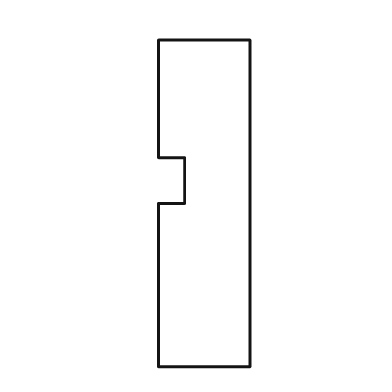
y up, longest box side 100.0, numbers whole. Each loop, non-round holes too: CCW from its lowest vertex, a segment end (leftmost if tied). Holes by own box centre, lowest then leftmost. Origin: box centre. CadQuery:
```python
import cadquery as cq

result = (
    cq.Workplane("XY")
    .moveTo(-14.0, -50.0)
    .lineTo(14.0, -50.0)
    .lineTo(14.0, 50.0)
    .lineTo(-14.0, 50.0)
    .lineTo(-14.0, 14.0)
    .lineTo(-6.0, 14.0)
    .lineTo(-6.0, 0.0)
    .lineTo(-14.0, 0.0)
    .close()
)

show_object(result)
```